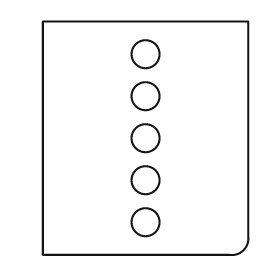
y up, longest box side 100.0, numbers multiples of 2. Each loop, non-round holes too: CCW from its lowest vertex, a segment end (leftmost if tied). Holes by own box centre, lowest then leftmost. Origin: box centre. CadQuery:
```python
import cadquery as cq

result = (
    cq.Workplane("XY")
    .moveTo(-44.0, -50.0)
    .lineTo(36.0, -50.0)
    .threePointArc((42.0, -48.0), (44.0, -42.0))
    .lineTo(44.0, 50.0)
    .lineTo(-44.0, 50.0)
    .close()
    .moveTo(0.0, -36.0)
    .circle(6.0)
    .moveTo(0.0, -18.0)
    .circle(6.0)
    .moveTo(0.0, 0.0)
    .circle(6.0)
    .moveTo(0.0, 18.0)
    .circle(6.0)
    .moveTo(0.0, 36.0)
    .circle(6.0)
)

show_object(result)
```